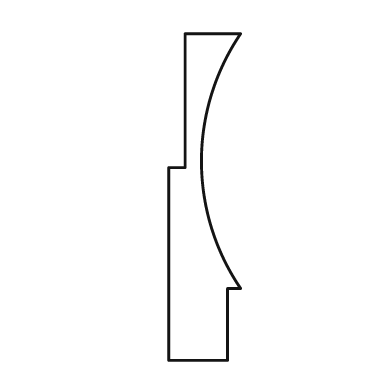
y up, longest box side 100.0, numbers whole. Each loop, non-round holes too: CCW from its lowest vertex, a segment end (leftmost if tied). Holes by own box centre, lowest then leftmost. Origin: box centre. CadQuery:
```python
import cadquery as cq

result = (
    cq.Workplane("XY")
    .moveTo(-11.0, -50.0)
    .lineTo(7.0, -50.0)
    .lineTo(7.0, -28.0)
    .lineTo(11.0, -28.0)
    .threePointArc((-1.0, 11.0), (11.0, 50.0))
    .lineTo(-6.0, 50.0)
    .lineTo(-6.0, 9.0)
    .lineTo(-11.0, 9.0)
    .close()
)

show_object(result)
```